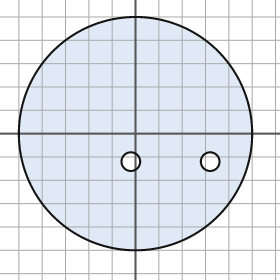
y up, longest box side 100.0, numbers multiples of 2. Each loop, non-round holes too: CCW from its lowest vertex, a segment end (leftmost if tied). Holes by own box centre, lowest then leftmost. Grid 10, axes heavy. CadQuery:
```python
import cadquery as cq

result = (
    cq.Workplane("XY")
    .moveTo(0.0, 0.0)
    .circle(50.0)
    .moveTo(-2.0, -12.0)
    .circle(4.0)
    .moveTo(32.0, -12.0)
    .circle(4.0)
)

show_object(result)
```